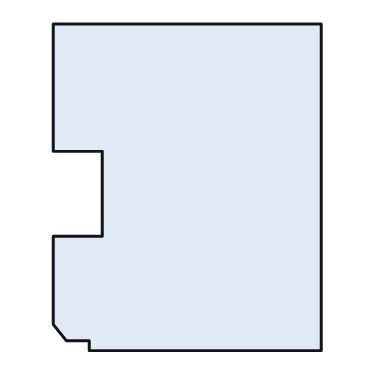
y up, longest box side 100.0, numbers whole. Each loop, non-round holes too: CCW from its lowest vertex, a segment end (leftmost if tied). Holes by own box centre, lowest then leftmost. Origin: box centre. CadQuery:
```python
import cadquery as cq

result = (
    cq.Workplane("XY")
    .moveTo(-30.0, -50.0)
    .lineTo(41.0, -50.0)
    .lineTo(41.0, 50.0)
    .lineTo(-41.0, 50.0)
    .lineTo(-41.0, 11.0)
    .lineTo(-26.0, 11.0)
    .lineTo(-26.0, -15.0)
    .lineTo(-41.0, -15.0)
    .lineTo(-41.0, -42.0)
    .lineTo(-37.0, -47.0)
    .lineTo(-30.0, -47.0)
    .close()
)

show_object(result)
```